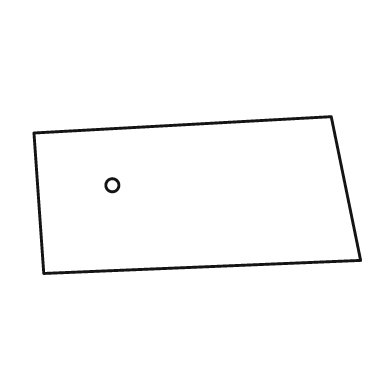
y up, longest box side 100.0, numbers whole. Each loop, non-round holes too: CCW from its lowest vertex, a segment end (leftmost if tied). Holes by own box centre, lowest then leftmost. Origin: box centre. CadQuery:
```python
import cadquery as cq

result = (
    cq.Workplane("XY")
    .moveTo(-47.0, -24.0)
    .lineTo(50.0, -20.0)
    .lineTo(41.0, 24.0)
    .lineTo(-50.0, 19.0)
    .close()
    .moveTo(-26.0, 3.0)
    .circle(2.0)
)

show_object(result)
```